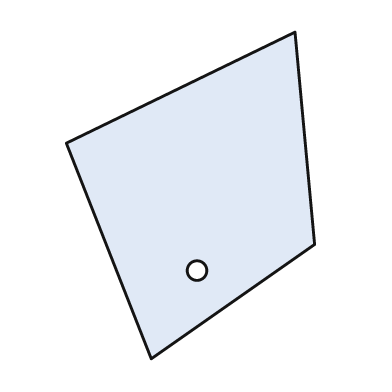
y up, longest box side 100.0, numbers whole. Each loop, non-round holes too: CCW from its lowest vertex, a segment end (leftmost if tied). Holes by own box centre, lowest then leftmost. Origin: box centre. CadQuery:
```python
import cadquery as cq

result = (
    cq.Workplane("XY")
    .moveTo(-12.0, -50.0)
    .lineTo(38.0, -15.0)
    .lineTo(32.0, 50.0)
    .lineTo(-38.0, 16.0)
    .close()
    .moveTo(2.0, -23.0)
    .circle(3.0)
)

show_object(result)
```